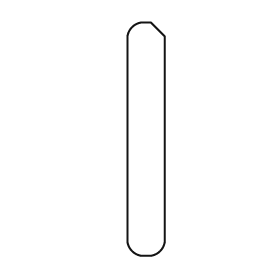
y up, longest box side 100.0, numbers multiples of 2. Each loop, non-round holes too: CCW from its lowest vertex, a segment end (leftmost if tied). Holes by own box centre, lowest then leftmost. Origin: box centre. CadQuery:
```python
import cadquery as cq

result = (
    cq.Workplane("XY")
    .moveTo(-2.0, -50.0)
    .lineTo(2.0, -50.0)
    .threePointArc((6.0, -48.0), (8.0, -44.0))
    .lineTo(8.0, 44.0)
    .lineTo(2.0, 50.0)
    .lineTo(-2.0, 50.0)
    .threePointArc((-6.0, 48.0), (-8.0, 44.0))
    .lineTo(-8.0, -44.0)
    .threePointArc((-6.0, -48.0), (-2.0, -50.0))
    .close()
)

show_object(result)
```